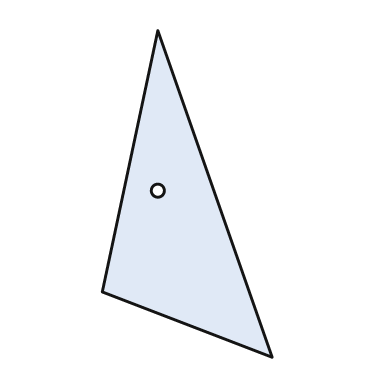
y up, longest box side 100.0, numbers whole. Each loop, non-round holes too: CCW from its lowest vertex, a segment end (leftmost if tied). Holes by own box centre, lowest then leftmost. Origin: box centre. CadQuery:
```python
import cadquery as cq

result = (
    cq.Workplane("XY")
    .moveTo(26.0, -50.0)
    .lineTo(-9.0, 50.0)
    .lineTo(-26.0, -30.0)
    .close()
    .moveTo(-9.0, 1.0)
    .circle(2.0)
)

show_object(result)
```